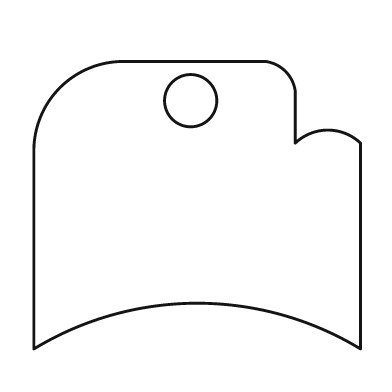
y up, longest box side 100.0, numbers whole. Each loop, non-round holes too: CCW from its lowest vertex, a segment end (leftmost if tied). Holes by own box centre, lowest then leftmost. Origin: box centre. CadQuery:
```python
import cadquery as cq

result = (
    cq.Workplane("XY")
    .moveTo(-50.0, -44.0)
    .threePointArc((0.0, -30.0), (50.0, -44.0))
    .lineTo(50.0, 19.0)
    .threePointArc((40.0, 23.0), (30.0, 19.0))
    .lineTo(30.0, 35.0)
    .threePointArc((27.0, 41.0), (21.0, 44.0))
    .lineTo(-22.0, 44.0)
    .threePointArc((-42.0, 36.0), (-50.0, 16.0))
    .close()
    .moveTo(-2.0, 32.0)
    .circle(8.0)
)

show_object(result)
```